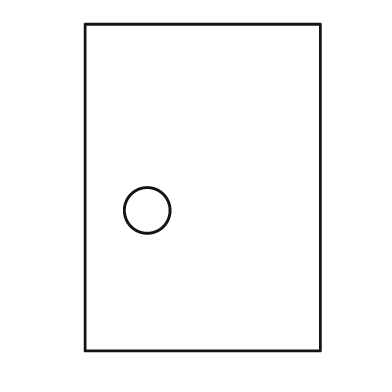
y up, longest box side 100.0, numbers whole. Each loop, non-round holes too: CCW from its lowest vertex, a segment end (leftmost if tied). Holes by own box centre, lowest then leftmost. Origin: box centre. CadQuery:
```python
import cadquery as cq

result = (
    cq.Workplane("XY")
    .moveTo(-36.0, -50.0)
    .lineTo(36.0, -50.0)
    .lineTo(36.0, 50.0)
    .lineTo(-36.0, 50.0)
    .close()
    .moveTo(-17.0, -7.0)
    .circle(7.0)
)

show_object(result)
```